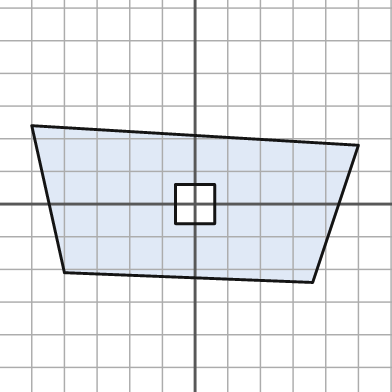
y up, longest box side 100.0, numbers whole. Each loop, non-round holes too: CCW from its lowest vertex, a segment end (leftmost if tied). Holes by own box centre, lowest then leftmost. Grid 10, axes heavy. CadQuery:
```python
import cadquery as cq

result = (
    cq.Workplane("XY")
    .moveTo(36.0, -24.0)
    .lineTo(50.0, 18.0)
    .lineTo(-50.0, 24.0)
    .lineTo(-40.0, -21.0)
    .close()
    .moveTo(-6.0, -6.0)
    .lineTo(6.0, -6.0)
    .lineTo(6.0, 6.0)
    .lineTo(-6.0, 6.0)
    .close()
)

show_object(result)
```